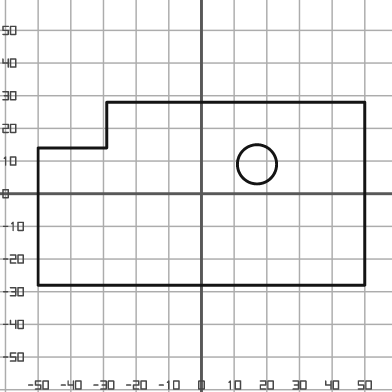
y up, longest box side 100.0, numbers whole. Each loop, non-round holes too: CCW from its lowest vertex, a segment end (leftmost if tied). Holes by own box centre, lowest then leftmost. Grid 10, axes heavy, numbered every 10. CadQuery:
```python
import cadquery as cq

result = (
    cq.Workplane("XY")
    .moveTo(-50.0, -28.0)
    .lineTo(50.0, -28.0)
    .lineTo(50.0, 28.0)
    .lineTo(-29.0, 28.0)
    .lineTo(-29.0, 14.0)
    .lineTo(-50.0, 14.0)
    .close()
    .moveTo(17.0, 9.0)
    .circle(6.0)
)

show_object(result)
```